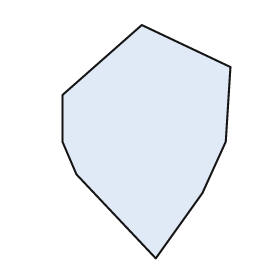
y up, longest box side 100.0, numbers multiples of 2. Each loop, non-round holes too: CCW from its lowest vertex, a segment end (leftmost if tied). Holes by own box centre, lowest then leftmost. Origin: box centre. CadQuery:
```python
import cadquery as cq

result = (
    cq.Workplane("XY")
    .moveTo(4.0, -50.0)
    .lineTo(24.0, -22.0)
    .lineTo(34.0, 0.0)
    .lineTo(36.0, 32.0)
    .lineTo(-2.0, 50.0)
    .lineTo(-36.0, 20.0)
    .lineTo(-36.0, 0.0)
    .lineTo(-30.0, -14.0)
    .close()
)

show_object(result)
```